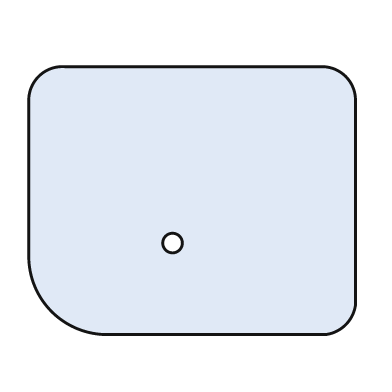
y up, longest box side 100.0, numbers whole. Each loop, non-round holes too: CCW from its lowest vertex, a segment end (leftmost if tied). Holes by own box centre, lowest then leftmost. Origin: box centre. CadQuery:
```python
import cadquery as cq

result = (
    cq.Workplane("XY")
    .moveTo(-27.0, -41.0)
    .lineTo(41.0, -41.0)
    .threePointArc((47.0, -38.0), (50.0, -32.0))
    .lineTo(50.0, 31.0)
    .threePointArc((47.0, 38.0), (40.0, 41.0))
    .lineTo(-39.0, 41.0)
    .threePointArc((-47.0, 38.0), (-50.0, 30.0))
    .lineTo(-50.0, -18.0)
    .threePointArc((-43.0, -34.0), (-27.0, -41.0))
    .close()
    .moveTo(-6.0, -13.0)
    .circle(3.0)
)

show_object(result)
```